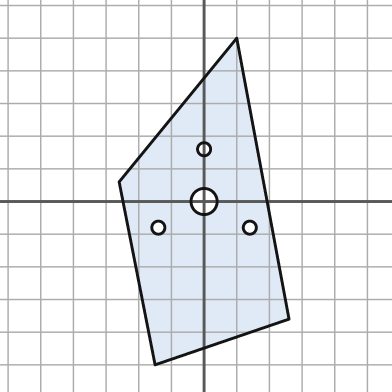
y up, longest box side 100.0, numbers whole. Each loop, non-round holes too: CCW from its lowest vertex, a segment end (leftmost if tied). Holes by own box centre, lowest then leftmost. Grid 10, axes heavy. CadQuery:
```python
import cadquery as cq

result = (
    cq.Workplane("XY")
    .moveTo(-15.0, -50.0)
    .lineTo(26.0, -36.0)
    .lineTo(10.0, 50.0)
    .lineTo(-26.0, 6.0)
    .close()
    .moveTo(-14.0, -8.0)
    .circle(2.0)
    .moveTo(14.0, -8.0)
    .circle(2.0)
    .moveTo(0.0, 0.0)
    .circle(4.0)
    .moveTo(0.0, 16.0)
    .circle(2.0)
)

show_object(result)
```